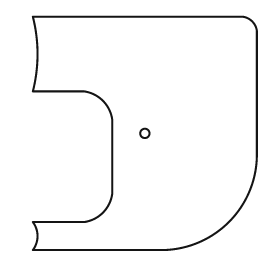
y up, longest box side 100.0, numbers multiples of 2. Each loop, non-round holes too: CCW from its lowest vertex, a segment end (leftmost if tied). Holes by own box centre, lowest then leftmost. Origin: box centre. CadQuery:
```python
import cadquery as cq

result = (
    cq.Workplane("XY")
    .moveTo(-48.0, -50.0)
    .lineTo(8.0, -50.0)
    .threePointArc((36.0, -38.0), (48.0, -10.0))
    .lineTo(48.0, 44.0)
    .threePointArc((46.0, 48.0), (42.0, 50.0))
    .lineTo(-48.0, 50.0)
    .threePointArc((-46.0, 34.0), (-48.0, 18.0))
    .lineTo(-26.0, 18.0)
    .threePointArc((-18.0, 14.0), (-14.0, 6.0))
    .lineTo(-14.0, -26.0)
    .threePointArc((-18.0, -34.0), (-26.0, -38.0))
    .lineTo(-48.0, -38.0)
    .threePointArc((-46.0, -44.0), (-48.0, -50.0))
    .close()
    .moveTo(0.0, 0.0)
    .circle(2.0)
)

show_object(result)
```